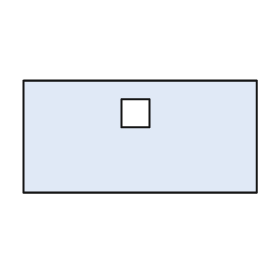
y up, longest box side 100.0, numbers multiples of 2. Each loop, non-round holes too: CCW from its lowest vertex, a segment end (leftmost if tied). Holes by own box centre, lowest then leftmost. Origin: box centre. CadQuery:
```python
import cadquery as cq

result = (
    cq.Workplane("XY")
    .moveTo(-50.0, -24.0)
    .lineTo(50.0, -24.0)
    .lineTo(50.0, 24.0)
    .lineTo(-50.0, 24.0)
    .close()
    .moveTo(-8.0, 4.0)
    .lineTo(4.0, 4.0)
    .lineTo(4.0, 16.0)
    .lineTo(-8.0, 16.0)
    .close()
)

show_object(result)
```